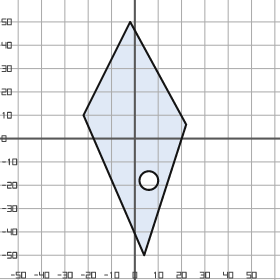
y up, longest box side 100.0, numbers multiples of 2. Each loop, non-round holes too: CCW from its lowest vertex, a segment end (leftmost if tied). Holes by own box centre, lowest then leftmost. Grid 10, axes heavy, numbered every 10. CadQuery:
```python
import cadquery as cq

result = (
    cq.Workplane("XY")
    .moveTo(4.0, -50.0)
    .lineTo(22.0, 6.0)
    .lineTo(-2.0, 50.0)
    .lineTo(-22.0, 10.0)
    .close()
    .moveTo(6.0, -18.0)
    .circle(4.0)
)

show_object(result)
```